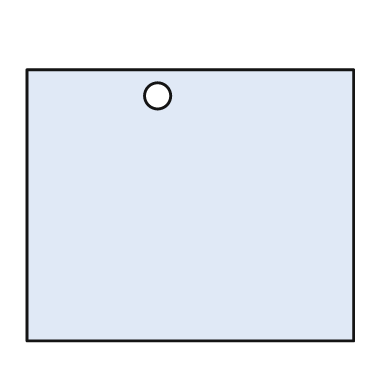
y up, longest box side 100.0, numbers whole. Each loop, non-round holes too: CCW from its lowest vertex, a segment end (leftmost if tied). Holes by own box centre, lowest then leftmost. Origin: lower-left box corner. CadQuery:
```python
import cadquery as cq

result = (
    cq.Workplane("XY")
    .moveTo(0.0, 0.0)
    .lineTo(100.0, 0.0)
    .lineTo(100.0, 83.0)
    .lineTo(0.0, 83.0)
    .close()
    .moveTo(40.0, 75.0)
    .circle(4.0)
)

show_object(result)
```